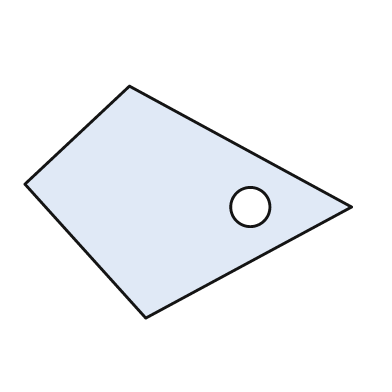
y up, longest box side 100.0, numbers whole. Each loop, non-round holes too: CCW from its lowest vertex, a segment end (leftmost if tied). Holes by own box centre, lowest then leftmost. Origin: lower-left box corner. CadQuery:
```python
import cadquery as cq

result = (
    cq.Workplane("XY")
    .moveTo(37.0, 0.0)
    .lineTo(100.0, 34.0)
    .lineTo(32.0, 71.0)
    .lineTo(0.0, 41.0)
    .close()
    .moveTo(69.0, 34.0)
    .circle(6.0)
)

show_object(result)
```